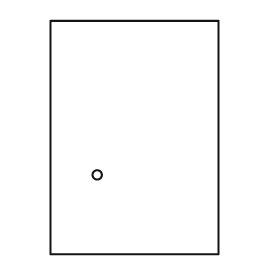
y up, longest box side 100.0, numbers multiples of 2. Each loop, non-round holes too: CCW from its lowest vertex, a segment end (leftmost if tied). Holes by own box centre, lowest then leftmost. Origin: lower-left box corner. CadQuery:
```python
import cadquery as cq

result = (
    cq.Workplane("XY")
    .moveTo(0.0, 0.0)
    .lineTo(72.0, 0.0)
    .lineTo(72.0, 100.0)
    .lineTo(0.0, 100.0)
    .close()
    .moveTo(20.0, 34.0)
    .circle(2.0)
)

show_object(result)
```